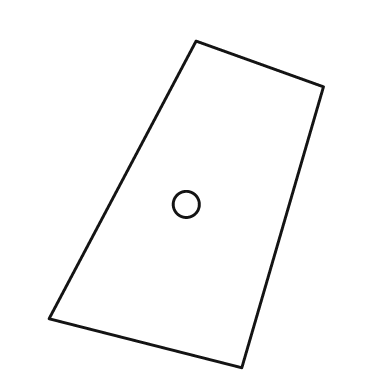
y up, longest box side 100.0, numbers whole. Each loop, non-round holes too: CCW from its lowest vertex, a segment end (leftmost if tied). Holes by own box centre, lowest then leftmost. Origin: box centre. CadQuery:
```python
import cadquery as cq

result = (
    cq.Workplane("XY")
    .moveTo(17.0, -50.0)
    .lineTo(42.0, 36.0)
    .lineTo(3.0, 50.0)
    .lineTo(-42.0, -35.0)
    .close()
    .moveTo(0.0, 0.0)
    .circle(4.0)
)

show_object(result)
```